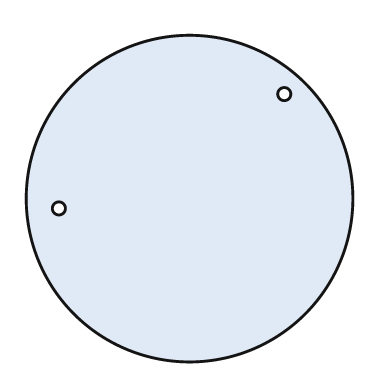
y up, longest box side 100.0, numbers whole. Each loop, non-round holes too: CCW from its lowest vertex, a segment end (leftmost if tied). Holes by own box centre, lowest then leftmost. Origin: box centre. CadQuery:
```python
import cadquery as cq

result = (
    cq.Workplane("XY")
    .moveTo(0.0, 0.0)
    .circle(50.0)
    .moveTo(-40.0, -3.0)
    .circle(2.0)
    .moveTo(29.0, 32.0)
    .circle(2.0)
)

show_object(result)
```